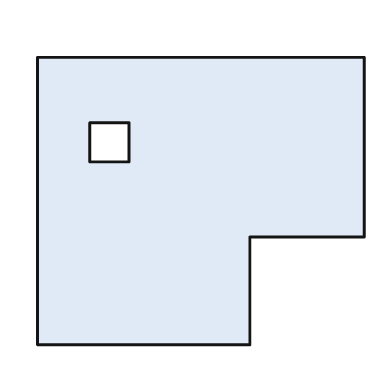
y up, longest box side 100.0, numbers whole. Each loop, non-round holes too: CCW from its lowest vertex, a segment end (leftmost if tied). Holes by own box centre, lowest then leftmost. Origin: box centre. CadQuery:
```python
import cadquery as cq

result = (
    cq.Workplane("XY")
    .moveTo(-50.0, -44.0)
    .lineTo(15.0, -44.0)
    .lineTo(15.0, -11.0)
    .lineTo(50.0, -11.0)
    .lineTo(50.0, 44.0)
    .lineTo(-50.0, 44.0)
    .close()
    .moveTo(-34.0, 12.0)
    .lineTo(-22.0, 12.0)
    .lineTo(-22.0, 24.0)
    .lineTo(-34.0, 24.0)
    .close()
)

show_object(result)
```